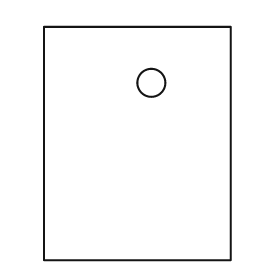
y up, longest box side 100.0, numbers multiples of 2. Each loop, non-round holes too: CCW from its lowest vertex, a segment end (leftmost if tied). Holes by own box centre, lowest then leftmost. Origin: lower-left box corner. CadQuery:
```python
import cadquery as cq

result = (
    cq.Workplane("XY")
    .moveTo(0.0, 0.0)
    .lineTo(80.0, 0.0)
    .lineTo(80.0, 100.0)
    .lineTo(0.0, 100.0)
    .close()
    .moveTo(46.0, 76.0)
    .circle(6.0)
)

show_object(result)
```